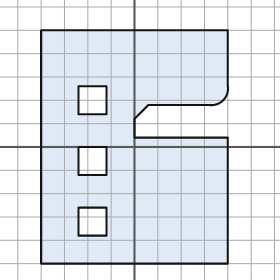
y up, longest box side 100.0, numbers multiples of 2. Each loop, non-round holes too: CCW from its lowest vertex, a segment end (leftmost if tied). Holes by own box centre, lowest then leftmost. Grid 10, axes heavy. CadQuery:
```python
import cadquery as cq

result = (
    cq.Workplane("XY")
    .moveTo(-40.0, -50.0)
    .lineTo(40.0, -50.0)
    .lineTo(40.0, 4.0)
    .lineTo(0.0, 4.0)
    .lineTo(0.0, 12.0)
    .lineTo(6.0, 18.0)
    .lineTo(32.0, 18.0)
    .threePointArc((38.0, 20.0), (40.0, 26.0))
    .lineTo(40.0, 50.0)
    .lineTo(-40.0, 50.0)
    .close()
    .moveTo(-24.0, -38.0)
    .lineTo(-12.0, -38.0)
    .lineTo(-12.0, -26.0)
    .lineTo(-24.0, -26.0)
    .close()
    .moveTo(-24.0, -12.0)
    .lineTo(-12.0, -12.0)
    .lineTo(-12.0, 0.0)
    .lineTo(-24.0, 0.0)
    .close()
    .moveTo(-24.0, 14.0)
    .lineTo(-12.0, 14.0)
    .lineTo(-12.0, 26.0)
    .lineTo(-24.0, 26.0)
    .close()
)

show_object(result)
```